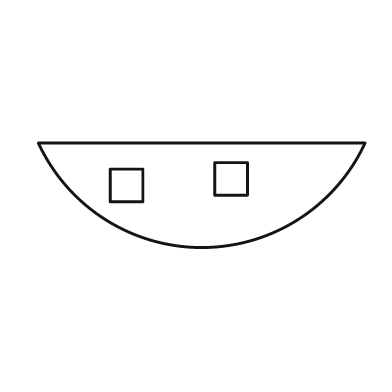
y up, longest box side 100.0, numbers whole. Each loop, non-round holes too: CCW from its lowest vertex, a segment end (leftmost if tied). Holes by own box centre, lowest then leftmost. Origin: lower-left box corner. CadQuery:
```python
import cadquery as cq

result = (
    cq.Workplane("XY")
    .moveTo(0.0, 32.0)
    .threePointArc((50.0, 0.0), (100.0, 32.0))
    .close()
    .moveTo(22.0, 14.0)
    .lineTo(32.0, 14.0)
    .lineTo(32.0, 24.0)
    .lineTo(22.0, 24.0)
    .close()
    .moveTo(54.0, 16.0)
    .lineTo(64.0, 16.0)
    .lineTo(64.0, 26.0)
    .lineTo(54.0, 26.0)
    .close()
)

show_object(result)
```